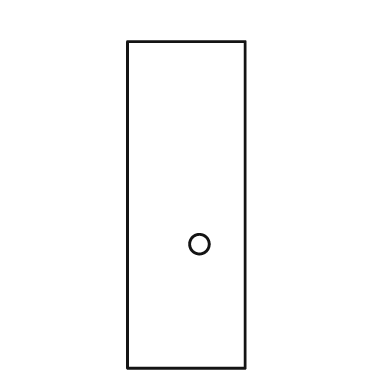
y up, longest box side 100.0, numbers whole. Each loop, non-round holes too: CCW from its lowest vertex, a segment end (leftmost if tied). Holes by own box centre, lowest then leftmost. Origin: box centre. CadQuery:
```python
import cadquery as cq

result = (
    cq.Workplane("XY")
    .moveTo(-18.0, -50.0)
    .lineTo(18.0, -50.0)
    .lineTo(18.0, 50.0)
    .lineTo(-18.0, 50.0)
    .close()
    .moveTo(4.0, -12.0)
    .circle(3.0)
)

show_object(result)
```